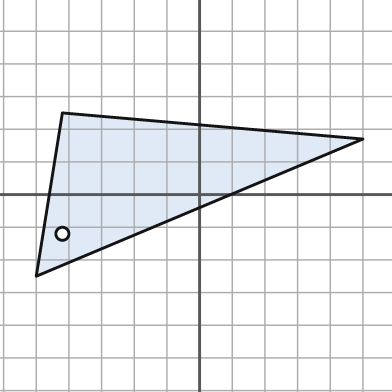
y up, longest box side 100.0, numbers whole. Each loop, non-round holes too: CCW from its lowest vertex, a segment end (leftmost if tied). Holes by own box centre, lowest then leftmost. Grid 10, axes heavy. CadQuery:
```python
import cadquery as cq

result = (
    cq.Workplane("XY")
    .moveTo(-50.0, -25.0)
    .lineTo(50.0, 17.0)
    .lineTo(-42.0, 25.0)
    .close()
    .moveTo(-42.0, -12.0)
    .circle(2.0)
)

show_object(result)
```